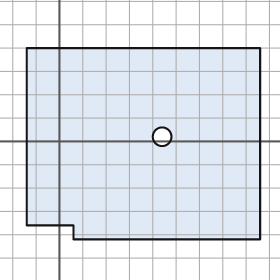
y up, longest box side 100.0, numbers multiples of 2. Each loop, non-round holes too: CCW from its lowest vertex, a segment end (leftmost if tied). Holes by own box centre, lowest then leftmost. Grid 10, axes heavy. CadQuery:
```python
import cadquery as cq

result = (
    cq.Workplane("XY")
    .moveTo(6.0, -42.0)
    .lineTo(86.0, -42.0)
    .lineTo(86.0, 40.0)
    .lineTo(-14.0, 40.0)
    .lineTo(-14.0, -36.0)
    .lineTo(6.0, -36.0)
    .close()
    .moveTo(44.0, 2.0)
    .circle(4.0)
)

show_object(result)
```